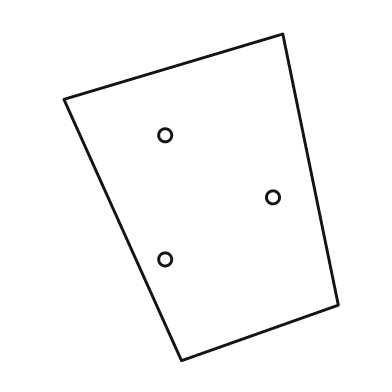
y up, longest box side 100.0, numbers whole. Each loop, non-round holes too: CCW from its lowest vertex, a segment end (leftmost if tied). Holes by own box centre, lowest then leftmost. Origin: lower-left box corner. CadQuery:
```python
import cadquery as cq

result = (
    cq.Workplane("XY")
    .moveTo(36.0, 0.0)
    .lineTo(84.0, 17.0)
    .lineTo(67.0, 100.0)
    .lineTo(0.0, 80.0)
    .close()
    .moveTo(31.0, 31.0)
    .circle(2.0)
    .moveTo(64.0, 50.0)
    .circle(2.0)
    .moveTo(31.0, 69.0)
    .circle(2.0)
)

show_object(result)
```